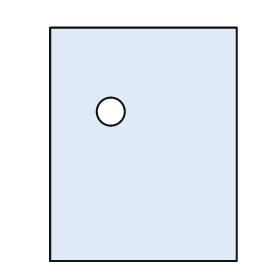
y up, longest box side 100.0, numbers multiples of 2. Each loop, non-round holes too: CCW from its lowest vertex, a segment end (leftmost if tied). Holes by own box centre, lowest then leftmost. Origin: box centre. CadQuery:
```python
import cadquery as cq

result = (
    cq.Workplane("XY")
    .moveTo(-40.0, -50.0)
    .lineTo(40.0, -50.0)
    .lineTo(40.0, 50.0)
    .lineTo(-40.0, 50.0)
    .close()
    .moveTo(-14.0, 14.0)
    .circle(6.0)
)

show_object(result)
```